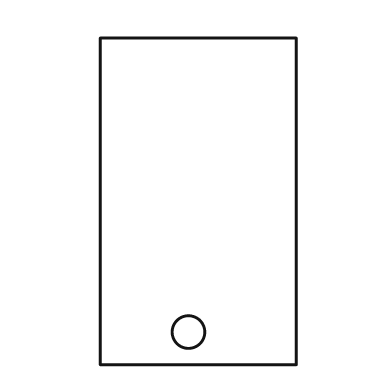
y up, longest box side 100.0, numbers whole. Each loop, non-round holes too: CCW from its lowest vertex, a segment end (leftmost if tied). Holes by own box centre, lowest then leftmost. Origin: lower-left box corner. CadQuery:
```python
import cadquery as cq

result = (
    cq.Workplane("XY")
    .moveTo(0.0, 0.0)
    .lineTo(60.0, 0.0)
    .lineTo(60.0, 100.0)
    .lineTo(0.0, 100.0)
    .close()
    .moveTo(27.0, 10.0)
    .circle(5.0)
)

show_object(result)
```